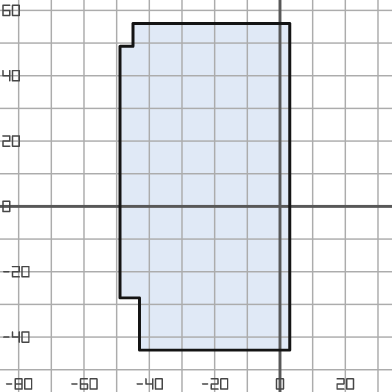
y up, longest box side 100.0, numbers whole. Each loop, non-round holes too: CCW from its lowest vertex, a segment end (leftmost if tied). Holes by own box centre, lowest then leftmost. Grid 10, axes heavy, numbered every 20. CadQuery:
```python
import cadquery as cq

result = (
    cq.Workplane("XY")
    .moveTo(-43.0, -44.0)
    .lineTo(3.0, -44.0)
    .lineTo(3.0, 56.0)
    .lineTo(-45.0, 56.0)
    .lineTo(-45.0, 49.0)
    .lineTo(-49.0, 49.0)
    .lineTo(-49.0, -28.0)
    .lineTo(-43.0, -28.0)
    .close()
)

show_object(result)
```